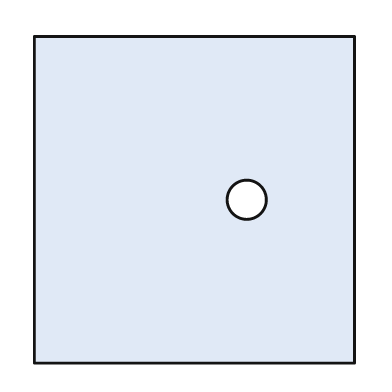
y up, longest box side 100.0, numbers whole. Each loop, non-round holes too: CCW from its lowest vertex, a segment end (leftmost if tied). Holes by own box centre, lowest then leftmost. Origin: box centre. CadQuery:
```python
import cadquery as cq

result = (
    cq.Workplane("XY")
    .moveTo(-49.0, -50.0)
    .lineTo(49.0, -50.0)
    .lineTo(49.0, 50.0)
    .lineTo(-49.0, 50.0)
    .close()
    .moveTo(16.0, 0.0)
    .circle(6.0)
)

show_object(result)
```